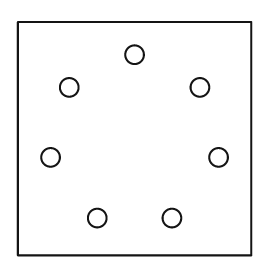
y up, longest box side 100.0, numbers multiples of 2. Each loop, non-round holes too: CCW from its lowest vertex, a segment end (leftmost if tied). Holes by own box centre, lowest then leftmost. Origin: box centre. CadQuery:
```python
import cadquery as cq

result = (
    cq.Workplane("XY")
    .moveTo(-50.0, -50.0)
    .lineTo(50.0, -50.0)
    .lineTo(50.0, 50.0)
    .lineTo(-50.0, 50.0)
    .close()
    .moveTo(-16.0, -34.0)
    .circle(4.0)
    .moveTo(16.0, -34.0)
    .circle(4.0)
    .moveTo(-36.0, -8.0)
    .circle(4.0)
    .moveTo(36.0, -8.0)
    .circle(4.0)
    .moveTo(-28.0, 22.0)
    .circle(4.0)
    .moveTo(28.0, 22.0)
    .circle(4.0)
    .moveTo(0.0, 36.0)
    .circle(4.0)
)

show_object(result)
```